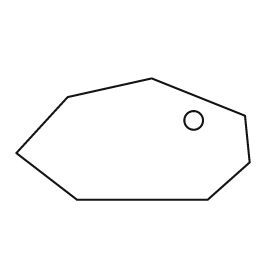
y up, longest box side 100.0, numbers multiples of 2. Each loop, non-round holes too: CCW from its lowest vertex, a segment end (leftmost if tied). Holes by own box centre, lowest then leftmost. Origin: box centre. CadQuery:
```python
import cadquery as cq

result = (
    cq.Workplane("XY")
    .moveTo(-24.0, -26.0)
    .lineTo(32.0, -26.0)
    .lineTo(50.0, -10.0)
    .lineTo(48.0, 10.0)
    .lineTo(8.0, 26.0)
    .lineTo(-28.0, 18.0)
    .lineTo(-50.0, -6.0)
    .close()
    .moveTo(26.0, 8.0)
    .circle(4.0)
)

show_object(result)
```